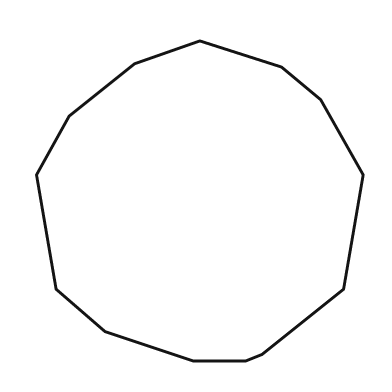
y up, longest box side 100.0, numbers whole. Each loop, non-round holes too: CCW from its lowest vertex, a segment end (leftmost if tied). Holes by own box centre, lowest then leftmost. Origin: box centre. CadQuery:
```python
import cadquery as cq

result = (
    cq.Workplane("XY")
    .moveTo(-2.0, -49.0)
    .lineTo(14.0, -49.0)
    .lineTo(19.0, -47.0)
    .lineTo(44.0, -27.0)
    .lineTo(50.0, 8.0)
    .lineTo(37.0, 31.0)
    .lineTo(25.0, 41.0)
    .lineTo(0.0, 49.0)
    .lineTo(-20.0, 42.0)
    .lineTo(-40.0, 26.0)
    .lineTo(-50.0, 8.0)
    .lineTo(-44.0, -27.0)
    .lineTo(-29.0, -40.0)
    .close()
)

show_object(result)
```